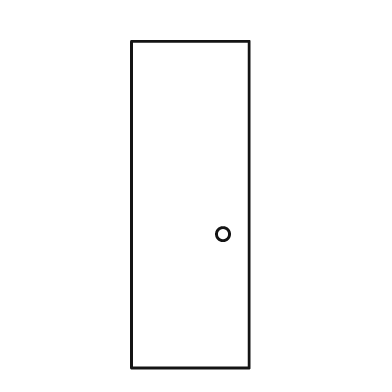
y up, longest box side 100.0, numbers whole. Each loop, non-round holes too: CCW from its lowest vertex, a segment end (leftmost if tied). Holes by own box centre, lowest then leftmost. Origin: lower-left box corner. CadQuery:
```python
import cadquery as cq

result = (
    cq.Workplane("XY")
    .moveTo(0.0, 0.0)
    .lineTo(36.0, 0.0)
    .lineTo(36.0, 100.0)
    .lineTo(0.0, 100.0)
    .close()
    .moveTo(28.0, 41.0)
    .circle(2.0)
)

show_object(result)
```